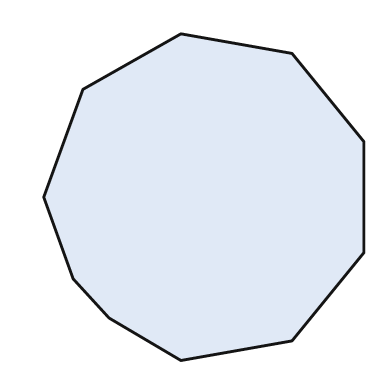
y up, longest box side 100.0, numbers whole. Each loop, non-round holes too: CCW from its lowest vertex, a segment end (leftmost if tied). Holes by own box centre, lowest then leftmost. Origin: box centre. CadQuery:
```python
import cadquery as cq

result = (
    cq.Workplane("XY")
    .moveTo(-7.0, -50.0)
    .lineTo(27.0, -44.0)
    .lineTo(49.0, -17.0)
    .lineTo(49.0, 17.0)
    .lineTo(27.0, 44.0)
    .lineTo(-7.0, 50.0)
    .lineTo(-37.0, 33.0)
    .lineTo(-49.0, 0.0)
    .lineTo(-40.0, -25.0)
    .lineTo(-29.0, -37.0)
    .close()
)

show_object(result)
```